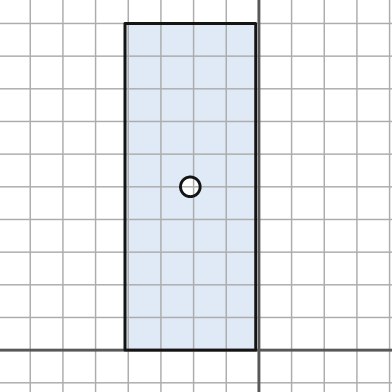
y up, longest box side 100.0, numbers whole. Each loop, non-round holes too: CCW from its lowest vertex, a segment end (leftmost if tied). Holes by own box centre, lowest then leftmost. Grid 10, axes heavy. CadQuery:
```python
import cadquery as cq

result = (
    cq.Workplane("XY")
    .moveTo(-41.0, 0.0)
    .lineTo(-1.0, 0.0)
    .lineTo(-1.0, 100.0)
    .lineTo(-41.0, 100.0)
    .close()
    .moveTo(-21.0, 50.0)
    .circle(3.0)
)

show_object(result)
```